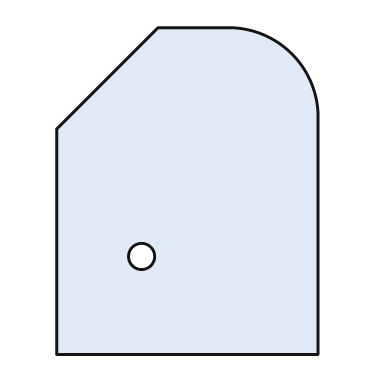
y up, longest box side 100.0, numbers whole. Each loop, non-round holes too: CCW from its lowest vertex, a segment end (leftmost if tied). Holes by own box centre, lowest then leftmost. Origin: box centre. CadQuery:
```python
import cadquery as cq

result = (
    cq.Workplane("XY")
    .moveTo(-40.0, -50.0)
    .lineTo(40.0, -50.0)
    .lineTo(40.0, 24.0)
    .threePointArc((32.0, 42.0), (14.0, 50.0))
    .lineTo(-9.0, 50.0)
    .lineTo(-40.0, 19.0)
    .close()
    .moveTo(-14.0, -20.0)
    .circle(4.0)
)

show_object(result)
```